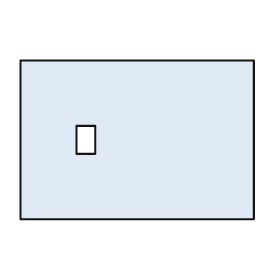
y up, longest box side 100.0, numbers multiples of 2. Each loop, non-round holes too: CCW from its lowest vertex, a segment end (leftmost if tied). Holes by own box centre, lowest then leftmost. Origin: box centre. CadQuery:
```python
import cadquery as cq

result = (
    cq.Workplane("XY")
    .moveTo(-50.0, -34.0)
    .lineTo(50.0, -34.0)
    .lineTo(50.0, 34.0)
    .lineTo(-50.0, 34.0)
    .close()
    .moveTo(-26.0, -6.0)
    .lineTo(-18.0, -6.0)
    .lineTo(-18.0, 6.0)
    .lineTo(-26.0, 6.0)
    .close()
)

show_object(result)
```